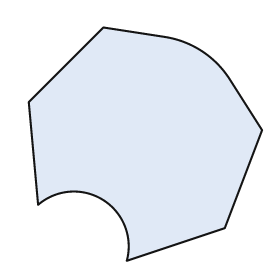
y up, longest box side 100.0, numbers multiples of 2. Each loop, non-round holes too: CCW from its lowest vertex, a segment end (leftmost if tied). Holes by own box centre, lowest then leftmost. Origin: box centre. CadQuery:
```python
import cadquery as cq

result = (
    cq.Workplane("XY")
    .moveTo(-8.0, -50.0)
    .lineTo(34.0, -36.0)
    .lineTo(50.0, 6.0)
    .lineTo(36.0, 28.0)
    .threePointArc((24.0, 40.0), (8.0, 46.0))
    .lineTo(-18.0, 50.0)
    .lineTo(-50.0, 18.0)
    .lineTo(-46.0, -26.0)
    .threePointArc((-18.0, -24.0), (-8.0, -50.0))
    .close()
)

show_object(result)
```